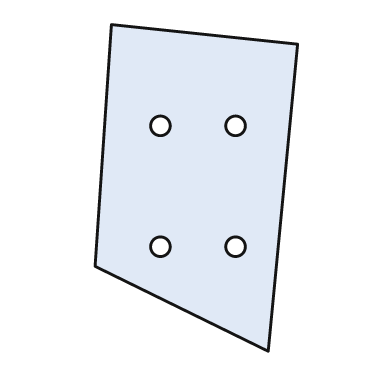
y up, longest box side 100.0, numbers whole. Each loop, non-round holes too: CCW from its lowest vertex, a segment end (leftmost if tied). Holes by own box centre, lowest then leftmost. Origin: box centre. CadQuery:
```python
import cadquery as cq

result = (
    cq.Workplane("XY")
    .moveTo(22.0, -50.0)
    .lineTo(31.0, 44.0)
    .lineTo(-26.0, 50.0)
    .lineTo(-31.0, -24.0)
    .close()
    .moveTo(-11.0, -18.0)
    .circle(3.0)
    .moveTo(12.0, -18.0)
    .circle(3.0)
    .moveTo(-11.0, 19.0)
    .circle(3.0)
    .moveTo(12.0, 19.0)
    .circle(3.0)
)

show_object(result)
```